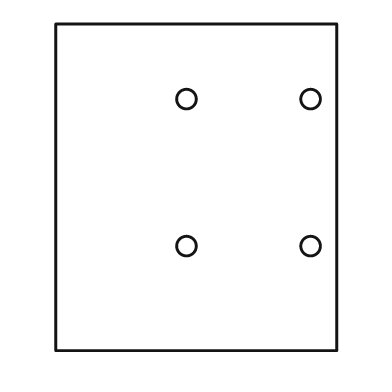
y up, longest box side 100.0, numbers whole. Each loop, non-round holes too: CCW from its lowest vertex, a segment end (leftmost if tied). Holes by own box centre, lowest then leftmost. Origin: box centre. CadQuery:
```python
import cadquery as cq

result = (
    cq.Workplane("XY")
    .moveTo(-43.0, -50.0)
    .lineTo(43.0, -50.0)
    .lineTo(43.0, 50.0)
    .lineTo(-43.0, 50.0)
    .close()
    .moveTo(-3.0, -18.0)
    .circle(3.0)
    .moveTo(35.0, -18.0)
    .circle(3.0)
    .moveTo(-3.0, 27.0)
    .circle(3.0)
    .moveTo(35.0, 27.0)
    .circle(3.0)
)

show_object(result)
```